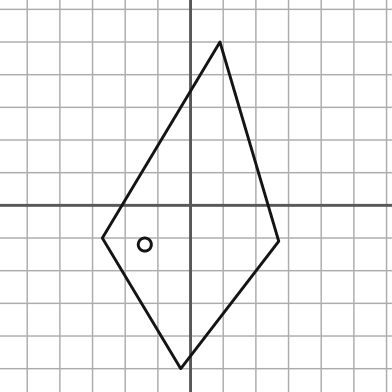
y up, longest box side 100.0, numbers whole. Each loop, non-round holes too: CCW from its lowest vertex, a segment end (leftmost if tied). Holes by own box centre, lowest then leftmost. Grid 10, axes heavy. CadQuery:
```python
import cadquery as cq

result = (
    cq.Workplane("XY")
    .moveTo(-3.0, -50.0)
    .lineTo(27.0, -11.0)
    .lineTo(9.0, 50.0)
    .lineTo(-27.0, -10.0)
    .close()
    .moveTo(-14.0, -12.0)
    .circle(2.0)
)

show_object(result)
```